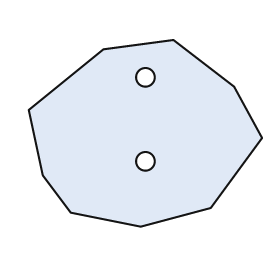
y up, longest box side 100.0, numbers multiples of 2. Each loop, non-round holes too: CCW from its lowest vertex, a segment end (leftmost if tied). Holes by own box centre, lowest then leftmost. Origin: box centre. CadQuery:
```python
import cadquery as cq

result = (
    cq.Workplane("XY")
    .moveTo(-2.0, -40.0)
    .lineTo(28.0, -32.0)
    .lineTo(50.0, -2.0)
    .lineTo(38.0, 20.0)
    .lineTo(12.0, 40.0)
    .lineTo(-18.0, 36.0)
    .lineTo(-50.0, 10.0)
    .lineTo(-44.0, -18.0)
    .lineTo(-32.0, -34.0)
    .close()
    .moveTo(0.0, -12.0)
    .circle(4.0)
    .moveTo(0.0, 24.0)
    .circle(4.0)
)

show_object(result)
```